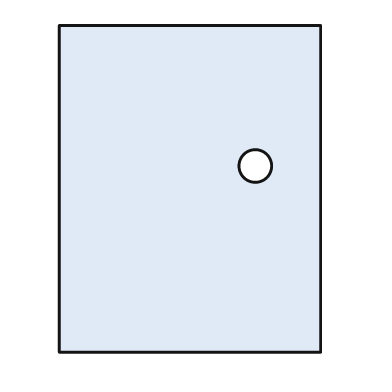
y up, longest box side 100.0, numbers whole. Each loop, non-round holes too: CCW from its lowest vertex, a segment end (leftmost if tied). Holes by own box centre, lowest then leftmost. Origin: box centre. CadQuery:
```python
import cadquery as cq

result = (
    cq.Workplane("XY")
    .moveTo(-40.0, -50.0)
    .lineTo(40.0, -50.0)
    .lineTo(40.0, 50.0)
    .lineTo(-40.0, 50.0)
    .close()
    .moveTo(20.0, 7.0)
    .circle(5.0)
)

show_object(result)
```